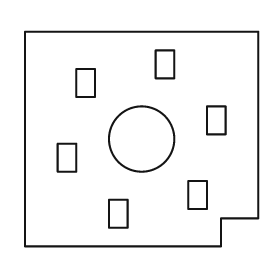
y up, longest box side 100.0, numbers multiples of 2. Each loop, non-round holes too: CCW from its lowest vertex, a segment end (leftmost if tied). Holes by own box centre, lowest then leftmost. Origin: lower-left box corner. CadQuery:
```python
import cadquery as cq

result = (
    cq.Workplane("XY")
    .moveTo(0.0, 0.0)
    .lineTo(84.0, 0.0)
    .lineTo(84.0, 12.0)
    .lineTo(100.0, 12.0)
    .lineTo(100.0, 92.0)
    .lineTo(0.0, 92.0)
    .close()
    .moveTo(36.0, 8.0)
    .lineTo(44.0, 8.0)
    .lineTo(44.0, 20.0)
    .lineTo(36.0, 20.0)
    .close()
    .moveTo(70.0, 16.0)
    .lineTo(78.0, 16.0)
    .lineTo(78.0, 28.0)
    .lineTo(70.0, 28.0)
    .close()
    .moveTo(14.0, 32.0)
    .lineTo(22.0, 32.0)
    .lineTo(22.0, 44.0)
    .lineTo(14.0, 44.0)
    .close()
    .moveTo(50.0, 46.0)
    .circle(14.0)
    .moveTo(78.0, 48.0)
    .lineTo(86.0, 48.0)
    .lineTo(86.0, 60.0)
    .lineTo(78.0, 60.0)
    .close()
    .moveTo(22.0, 64.0)
    .lineTo(30.0, 64.0)
    .lineTo(30.0, 76.0)
    .lineTo(22.0, 76.0)
    .close()
    .moveTo(56.0, 72.0)
    .lineTo(64.0, 72.0)
    .lineTo(64.0, 84.0)
    .lineTo(56.0, 84.0)
    .close()
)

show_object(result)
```